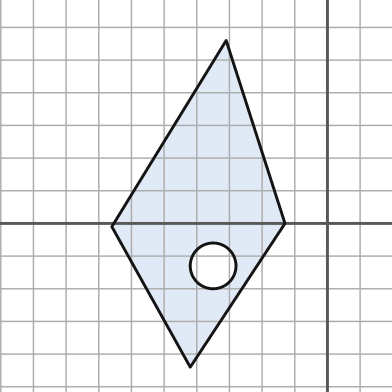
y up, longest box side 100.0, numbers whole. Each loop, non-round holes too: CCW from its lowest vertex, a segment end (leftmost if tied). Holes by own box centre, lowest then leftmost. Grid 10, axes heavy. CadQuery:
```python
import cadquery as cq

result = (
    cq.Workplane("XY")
    .moveTo(-42.0, -44.0)
    .lineTo(-13.0, 0.0)
    .lineTo(-31.0, 56.0)
    .lineTo(-66.0, -1.0)
    .close()
    .moveTo(-35.0, -13.0)
    .circle(7.0)
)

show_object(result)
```